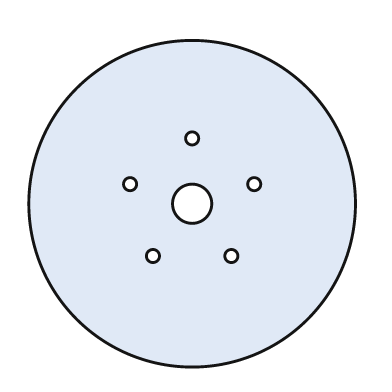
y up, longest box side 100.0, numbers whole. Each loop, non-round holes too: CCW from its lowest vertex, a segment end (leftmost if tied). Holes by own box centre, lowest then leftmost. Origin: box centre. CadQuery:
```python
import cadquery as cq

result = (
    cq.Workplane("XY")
    .moveTo(0.0, 0.0)
    .circle(50.0)
    .moveTo(-12.0, -16.0)
    .circle(2.0)
    .moveTo(12.0, -16.0)
    .circle(2.0)
    .moveTo(0.0, 0.0)
    .circle(6.0)
    .moveTo(-19.0, 6.0)
    .circle(2.0)
    .moveTo(19.0, 6.0)
    .circle(2.0)
    .moveTo(0.0, 20.0)
    .circle(2.0)
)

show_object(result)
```